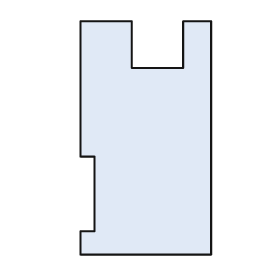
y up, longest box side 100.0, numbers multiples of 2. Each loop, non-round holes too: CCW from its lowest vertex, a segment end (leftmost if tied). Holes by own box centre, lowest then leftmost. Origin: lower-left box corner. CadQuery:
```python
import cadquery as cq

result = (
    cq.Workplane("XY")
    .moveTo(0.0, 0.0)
    .lineTo(56.0, 0.0)
    .lineTo(56.0, 100.0)
    .lineTo(44.0, 100.0)
    .lineTo(44.0, 80.0)
    .lineTo(22.0, 80.0)
    .lineTo(22.0, 100.0)
    .lineTo(0.0, 100.0)
    .lineTo(0.0, 42.0)
    .lineTo(6.0, 42.0)
    .lineTo(6.0, 10.0)
    .lineTo(0.0, 10.0)
    .close()
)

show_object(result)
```